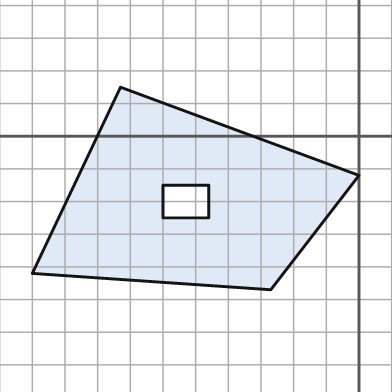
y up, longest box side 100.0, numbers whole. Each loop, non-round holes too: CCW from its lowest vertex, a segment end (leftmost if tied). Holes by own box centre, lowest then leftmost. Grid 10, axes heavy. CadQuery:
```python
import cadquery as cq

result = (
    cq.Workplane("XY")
    .moveTo(-27.0, -47.0)
    .lineTo(0.0, -12.0)
    .lineTo(-73.0, 15.0)
    .lineTo(-100.0, -42.0)
    .close()
    .moveTo(-60.0, -25.0)
    .lineTo(-46.0, -25.0)
    .lineTo(-46.0, -15.0)
    .lineTo(-60.0, -15.0)
    .close()
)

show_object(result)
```